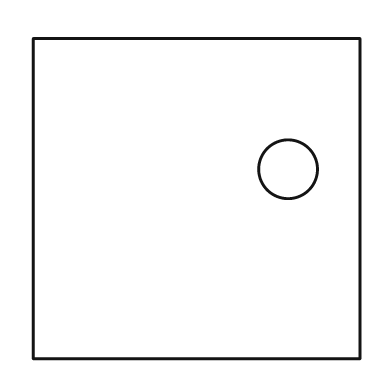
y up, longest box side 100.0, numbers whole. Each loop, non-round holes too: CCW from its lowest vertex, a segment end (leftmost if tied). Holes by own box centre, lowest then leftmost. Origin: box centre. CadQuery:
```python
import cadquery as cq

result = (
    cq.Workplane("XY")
    .moveTo(-50.0, -49.0)
    .lineTo(50.0, -49.0)
    .lineTo(50.0, 49.0)
    .lineTo(-50.0, 49.0)
    .close()
    .moveTo(28.0, 9.0)
    .circle(9.0)
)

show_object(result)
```